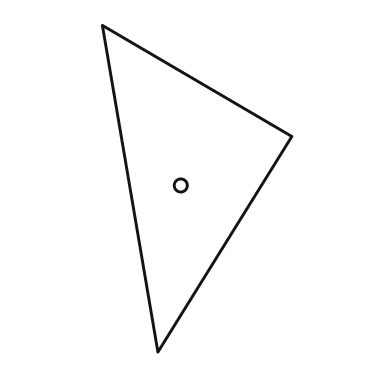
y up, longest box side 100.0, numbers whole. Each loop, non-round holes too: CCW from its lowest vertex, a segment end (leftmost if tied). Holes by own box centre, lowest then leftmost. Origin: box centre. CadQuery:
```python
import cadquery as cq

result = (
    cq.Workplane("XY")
    .moveTo(-12.0, -50.0)
    .lineTo(29.0, 16.0)
    .lineTo(-29.0, 50.0)
    .close()
    .moveTo(-5.0, 1.0)
    .circle(2.0)
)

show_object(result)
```